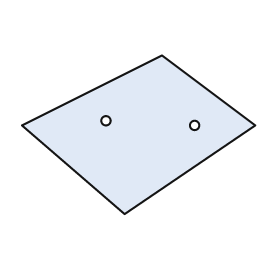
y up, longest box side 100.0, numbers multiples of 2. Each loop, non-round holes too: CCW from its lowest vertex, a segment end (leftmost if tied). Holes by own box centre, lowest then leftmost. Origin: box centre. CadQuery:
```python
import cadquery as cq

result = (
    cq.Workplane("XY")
    .moveTo(-6.0, -34.0)
    .lineTo(50.0, 4.0)
    .lineTo(10.0, 34.0)
    .lineTo(-50.0, 4.0)
    .close()
    .moveTo(24.0, 4.0)
    .circle(2.0)
    .moveTo(-14.0, 6.0)
    .circle(2.0)
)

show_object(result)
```